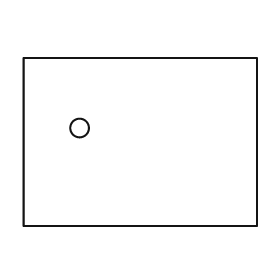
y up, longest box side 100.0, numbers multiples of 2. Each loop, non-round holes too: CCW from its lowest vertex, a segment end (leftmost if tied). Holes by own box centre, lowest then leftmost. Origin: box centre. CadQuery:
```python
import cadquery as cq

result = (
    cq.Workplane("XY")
    .moveTo(-50.0, -36.0)
    .lineTo(50.0, -36.0)
    .lineTo(50.0, 36.0)
    .lineTo(-50.0, 36.0)
    .close()
    .moveTo(-26.0, 6.0)
    .circle(4.0)
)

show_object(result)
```